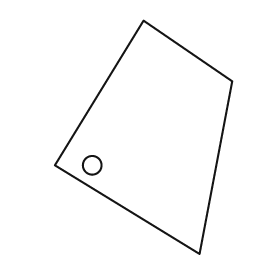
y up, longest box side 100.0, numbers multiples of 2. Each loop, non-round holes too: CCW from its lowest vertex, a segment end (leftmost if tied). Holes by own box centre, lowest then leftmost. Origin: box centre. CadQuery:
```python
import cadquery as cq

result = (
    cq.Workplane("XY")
    .moveTo(24.0, -50.0)
    .lineTo(38.0, 24.0)
    .lineTo(0.0, 50.0)
    .lineTo(-38.0, -12.0)
    .close()
    .moveTo(-22.0, -12.0)
    .circle(4.0)
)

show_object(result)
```